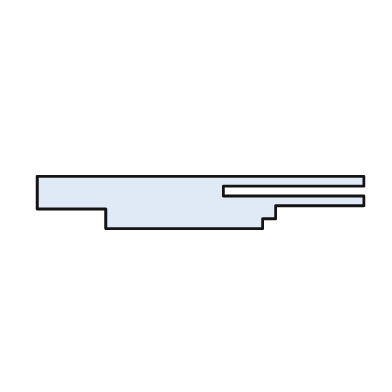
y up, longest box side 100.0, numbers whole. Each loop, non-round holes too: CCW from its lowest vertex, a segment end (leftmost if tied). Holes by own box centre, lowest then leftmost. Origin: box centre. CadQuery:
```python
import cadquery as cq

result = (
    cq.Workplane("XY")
    .moveTo(-29.0, -8.0)
    .lineTo(19.0, -8.0)
    .lineTo(19.0, -5.0)
    .lineTo(23.0, -5.0)
    .lineTo(23.0, -1.0)
    .lineTo(50.0, -1.0)
    .lineTo(50.0, 2.0)
    .lineTo(7.0, 2.0)
    .lineTo(7.0, 5.0)
    .lineTo(50.0, 5.0)
    .lineTo(50.0, 8.0)
    .lineTo(-50.0, 8.0)
    .lineTo(-50.0, -2.0)
    .lineTo(-29.0, -2.0)
    .close()
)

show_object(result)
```